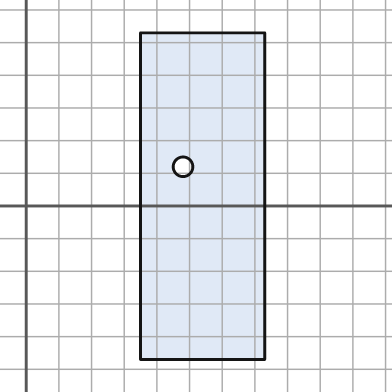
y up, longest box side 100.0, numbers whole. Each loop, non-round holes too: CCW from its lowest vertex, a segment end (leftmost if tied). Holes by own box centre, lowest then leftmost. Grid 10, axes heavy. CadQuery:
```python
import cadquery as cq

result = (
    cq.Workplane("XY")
    .moveTo(35.0, -47.0)
    .lineTo(73.0, -47.0)
    .lineTo(73.0, 53.0)
    .lineTo(35.0, 53.0)
    .close()
    .moveTo(48.0, 12.0)
    .circle(3.0)
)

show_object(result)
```